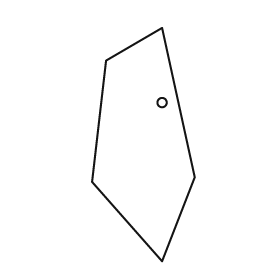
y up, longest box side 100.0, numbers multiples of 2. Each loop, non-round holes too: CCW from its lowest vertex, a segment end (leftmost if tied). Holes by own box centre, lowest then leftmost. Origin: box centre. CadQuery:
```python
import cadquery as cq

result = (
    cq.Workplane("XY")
    .moveTo(8.0, -50.0)
    .lineTo(22.0, -14.0)
    .lineTo(8.0, 50.0)
    .lineTo(-16.0, 36.0)
    .lineTo(-22.0, -16.0)
    .close()
    .moveTo(8.0, 18.0)
    .circle(2.0)
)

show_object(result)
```